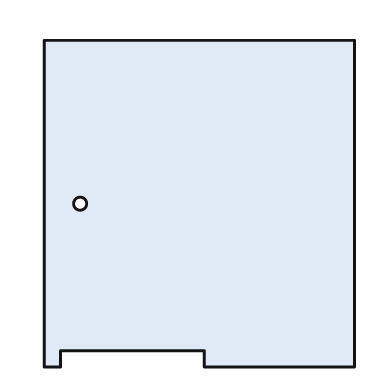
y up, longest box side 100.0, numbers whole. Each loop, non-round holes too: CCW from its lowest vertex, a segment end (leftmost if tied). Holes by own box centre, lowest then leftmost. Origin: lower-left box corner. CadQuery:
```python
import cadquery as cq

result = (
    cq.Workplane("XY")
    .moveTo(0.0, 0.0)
    .lineTo(5.0, 0.0)
    .lineTo(5.0, 5.0)
    .lineTo(49.0, 5.0)
    .lineTo(49.0, 0.0)
    .lineTo(95.0, 0.0)
    .lineTo(95.0, 100.0)
    .lineTo(0.0, 100.0)
    .close()
    .moveTo(11.0, 50.0)
    .circle(2.0)
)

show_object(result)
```